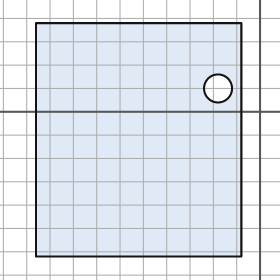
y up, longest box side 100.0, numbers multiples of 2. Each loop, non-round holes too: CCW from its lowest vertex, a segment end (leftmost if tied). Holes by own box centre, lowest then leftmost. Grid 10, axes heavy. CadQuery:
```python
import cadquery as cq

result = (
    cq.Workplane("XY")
    .moveTo(-96.0, -62.0)
    .lineTo(-8.0, -62.0)
    .lineTo(-8.0, 38.0)
    .lineTo(-96.0, 38.0)
    .close()
    .moveTo(-18.0, 10.0)
    .circle(6.0)
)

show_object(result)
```